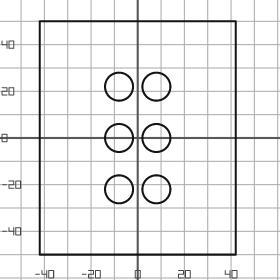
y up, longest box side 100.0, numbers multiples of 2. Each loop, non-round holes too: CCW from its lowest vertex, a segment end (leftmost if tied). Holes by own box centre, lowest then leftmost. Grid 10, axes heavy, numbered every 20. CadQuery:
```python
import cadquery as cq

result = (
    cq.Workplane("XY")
    .moveTo(-42.0, -50.0)
    .lineTo(42.0, -50.0)
    .lineTo(42.0, 50.0)
    .lineTo(-42.0, 50.0)
    .close()
    .moveTo(-8.0, -22.0)
    .circle(6.0)
    .moveTo(8.0, -22.0)
    .circle(6.0)
    .moveTo(-8.0, 0.0)
    .circle(6.0)
    .moveTo(8.0, 0.0)
    .circle(6.0)
    .moveTo(-8.0, 22.0)
    .circle(6.0)
    .moveTo(8.0, 22.0)
    .circle(6.0)
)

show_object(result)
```